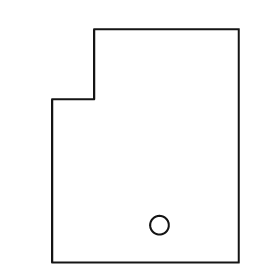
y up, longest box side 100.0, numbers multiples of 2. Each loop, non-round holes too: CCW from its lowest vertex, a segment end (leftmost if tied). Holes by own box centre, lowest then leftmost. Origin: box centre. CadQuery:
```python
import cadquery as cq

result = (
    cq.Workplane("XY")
    .moveTo(-40.0, -50.0)
    .lineTo(40.0, -50.0)
    .lineTo(40.0, 50.0)
    .lineTo(-22.0, 50.0)
    .lineTo(-22.0, 20.0)
    .lineTo(-40.0, 20.0)
    .close()
    .moveTo(6.0, -34.0)
    .circle(4.0)
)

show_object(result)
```